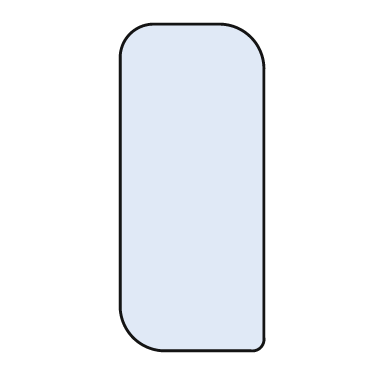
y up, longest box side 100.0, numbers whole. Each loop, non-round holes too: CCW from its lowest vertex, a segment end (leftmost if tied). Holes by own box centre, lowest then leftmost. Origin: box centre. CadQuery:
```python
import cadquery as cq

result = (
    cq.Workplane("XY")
    .moveTo(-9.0, -50.0)
    .lineTo(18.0, -50.0)
    .threePointArc((21.0, -49.0), (22.0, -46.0))
    .lineTo(22.0, 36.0)
    .threePointArc((18.0, 46.0), (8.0, 50.0))
    .lineTo(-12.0, 50.0)
    .threePointArc((-19.0, 47.0), (-22.0, 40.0))
    .lineTo(-22.0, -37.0)
    .threePointArc((-18.0, -46.0), (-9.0, -50.0))
    .close()
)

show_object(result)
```